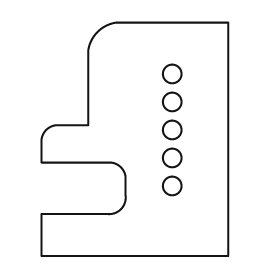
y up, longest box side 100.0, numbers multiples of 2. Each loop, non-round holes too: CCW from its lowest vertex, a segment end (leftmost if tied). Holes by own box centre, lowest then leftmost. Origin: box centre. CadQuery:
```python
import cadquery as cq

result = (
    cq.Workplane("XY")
    .moveTo(-40.0, -50.0)
    .lineTo(40.0, -50.0)
    .lineTo(40.0, 50.0)
    .lineTo(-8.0, 50.0)
    .threePointArc((-16.0, 46.0), (-20.0, 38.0))
    .lineTo(-20.0, 6.0)
    .lineTo(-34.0, 6.0)
    .threePointArc((-38.0, 4.0), (-40.0, 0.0))
    .lineTo(-40.0, -10.0)
    .lineTo(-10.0, -10.0)
    .threePointArc((-6.0, -12.0), (-4.0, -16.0))
    .lineTo(-4.0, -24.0)
    .threePointArc((-6.0, -30.0), (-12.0, -32.0))
    .lineTo(-40.0, -32.0)
    .close()
    .moveTo(16.0, -20.0)
    .circle(4.0)
    .moveTo(16.0, -8.0)
    .circle(4.0)
    .moveTo(16.0, 4.0)
    .circle(4.0)
    .moveTo(16.0, 16.0)
    .circle(4.0)
    .moveTo(16.0, 28.0)
    .circle(4.0)
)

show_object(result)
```